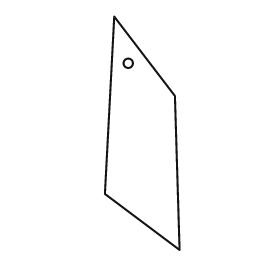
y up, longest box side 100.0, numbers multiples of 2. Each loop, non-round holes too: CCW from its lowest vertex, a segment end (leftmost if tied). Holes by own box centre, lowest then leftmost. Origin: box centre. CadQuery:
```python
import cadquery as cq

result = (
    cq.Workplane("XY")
    .moveTo(16.0, -50.0)
    .lineTo(14.0, 16.0)
    .lineTo(-12.0, 50.0)
    .lineTo(-16.0, -26.0)
    .close()
    .moveTo(-6.0, 30.0)
    .circle(2.0)
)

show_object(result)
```